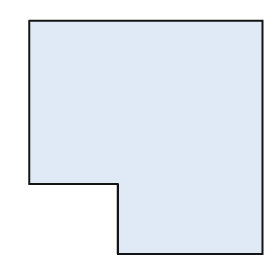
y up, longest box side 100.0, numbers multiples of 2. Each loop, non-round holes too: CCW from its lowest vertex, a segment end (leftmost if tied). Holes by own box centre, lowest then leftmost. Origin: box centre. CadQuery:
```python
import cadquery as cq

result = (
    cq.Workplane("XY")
    .moveTo(-12.0, -50.0)
    .lineTo(50.0, -50.0)
    .lineTo(50.0, 50.0)
    .lineTo(-50.0, 50.0)
    .lineTo(-50.0, -20.0)
    .lineTo(-12.0, -20.0)
    .close()
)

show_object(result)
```